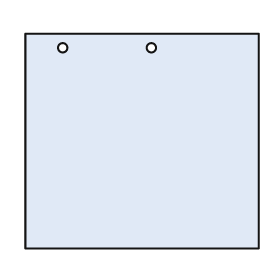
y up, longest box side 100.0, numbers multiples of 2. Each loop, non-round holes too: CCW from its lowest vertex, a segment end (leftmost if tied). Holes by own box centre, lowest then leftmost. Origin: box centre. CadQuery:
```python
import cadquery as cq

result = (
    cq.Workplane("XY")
    .moveTo(-50.0, -46.0)
    .lineTo(50.0, -46.0)
    .lineTo(50.0, 46.0)
    .lineTo(-50.0, 46.0)
    .close()
    .moveTo(-34.0, 40.0)
    .circle(2.0)
    .moveTo(4.0, 40.0)
    .circle(2.0)
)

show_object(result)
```